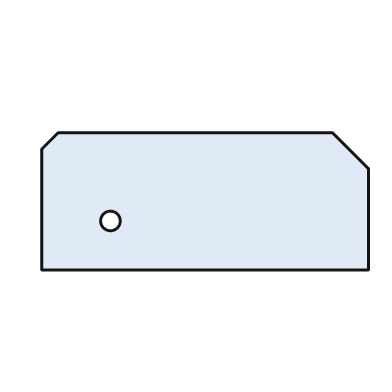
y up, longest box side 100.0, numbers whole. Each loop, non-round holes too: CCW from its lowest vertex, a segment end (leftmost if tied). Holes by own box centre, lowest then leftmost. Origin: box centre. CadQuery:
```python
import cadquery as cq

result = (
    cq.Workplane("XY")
    .moveTo(-50.0, -21.0)
    .lineTo(50.0, -21.0)
    .lineTo(50.0, 10.0)
    .lineTo(39.0, 21.0)
    .lineTo(-45.0, 21.0)
    .lineTo(-50.0, 16.0)
    .close()
    .moveTo(-29.0, -6.0)
    .circle(3.0)
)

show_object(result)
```